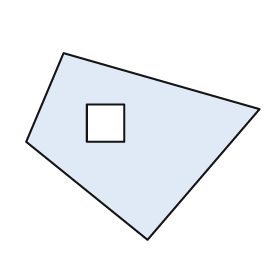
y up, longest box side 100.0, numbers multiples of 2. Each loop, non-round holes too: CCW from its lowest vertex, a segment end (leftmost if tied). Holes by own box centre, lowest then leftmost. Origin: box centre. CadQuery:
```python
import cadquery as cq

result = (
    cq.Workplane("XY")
    .moveTo(2.0, -40.0)
    .lineTo(50.0, 16.0)
    .lineTo(-34.0, 40.0)
    .lineTo(-50.0, 2.0)
    .close()
    .moveTo(-24.0, 2.0)
    .lineTo(-8.0, 2.0)
    .lineTo(-8.0, 18.0)
    .lineTo(-24.0, 18.0)
    .close()
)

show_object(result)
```